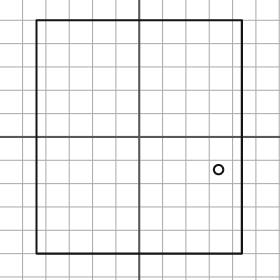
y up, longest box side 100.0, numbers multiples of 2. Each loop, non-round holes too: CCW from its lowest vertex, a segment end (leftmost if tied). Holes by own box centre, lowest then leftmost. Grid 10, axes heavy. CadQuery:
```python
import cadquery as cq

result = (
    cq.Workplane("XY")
    .moveTo(-44.0, -50.0)
    .lineTo(44.0, -50.0)
    .lineTo(44.0, 50.0)
    .lineTo(-44.0, 50.0)
    .close()
    .moveTo(34.0, -14.0)
    .circle(2.0)
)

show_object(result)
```